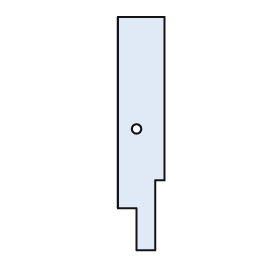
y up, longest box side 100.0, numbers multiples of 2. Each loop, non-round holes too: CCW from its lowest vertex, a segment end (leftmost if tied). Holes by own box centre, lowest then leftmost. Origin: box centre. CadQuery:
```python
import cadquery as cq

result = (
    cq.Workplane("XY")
    .moveTo(-2.0, -50.0)
    .lineTo(6.0, -50.0)
    .lineTo(6.0, -20.0)
    .lineTo(10.0, -20.0)
    .lineTo(10.0, 50.0)
    .lineTo(-10.0, 50.0)
    .lineTo(-10.0, -32.0)
    .lineTo(-2.0, -32.0)
    .close()
    .moveTo(-2.0, 2.0)
    .circle(2.0)
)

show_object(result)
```